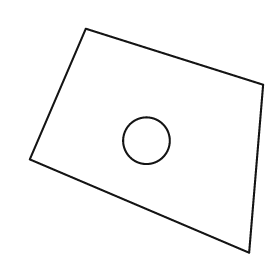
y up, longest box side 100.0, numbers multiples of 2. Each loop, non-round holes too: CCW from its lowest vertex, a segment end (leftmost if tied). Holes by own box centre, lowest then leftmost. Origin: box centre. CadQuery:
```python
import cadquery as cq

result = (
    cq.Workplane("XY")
    .moveTo(44.0, -48.0)
    .lineTo(50.0, 24.0)
    .lineTo(-26.0, 48.0)
    .lineTo(-50.0, -8.0)
    .close()
    .moveTo(0.0, 0.0)
    .circle(10.0)
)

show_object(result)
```